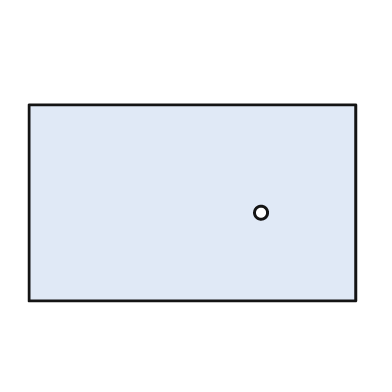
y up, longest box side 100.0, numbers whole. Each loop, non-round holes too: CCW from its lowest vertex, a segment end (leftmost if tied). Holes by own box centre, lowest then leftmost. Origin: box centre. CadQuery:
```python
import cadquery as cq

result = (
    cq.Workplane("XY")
    .moveTo(-50.0, -30.0)
    .lineTo(50.0, -30.0)
    .lineTo(50.0, 30.0)
    .lineTo(-50.0, 30.0)
    .close()
    .moveTo(21.0, -3.0)
    .circle(2.0)
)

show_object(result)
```